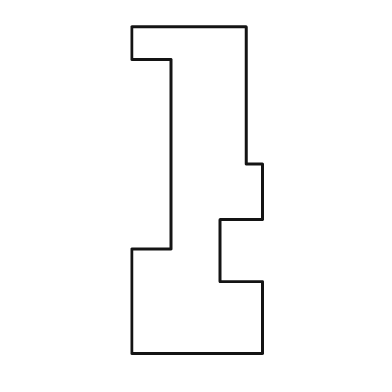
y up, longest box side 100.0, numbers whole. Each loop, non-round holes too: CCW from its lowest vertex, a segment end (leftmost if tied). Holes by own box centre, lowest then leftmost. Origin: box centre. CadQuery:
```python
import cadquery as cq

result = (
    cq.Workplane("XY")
    .moveTo(-20.0, -50.0)
    .lineTo(20.0, -50.0)
    .lineTo(20.0, -28.0)
    .lineTo(7.0, -28.0)
    .lineTo(7.0, -9.0)
    .lineTo(20.0, -9.0)
    .lineTo(20.0, 8.0)
    .lineTo(15.0, 8.0)
    .lineTo(15.0, 50.0)
    .lineTo(-20.0, 50.0)
    .lineTo(-20.0, 40.0)
    .lineTo(-8.0, 40.0)
    .lineTo(-8.0, -18.0)
    .lineTo(-20.0, -18.0)
    .close()
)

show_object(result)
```